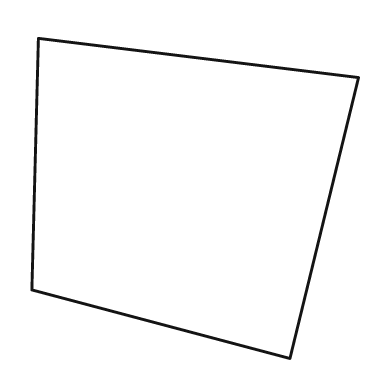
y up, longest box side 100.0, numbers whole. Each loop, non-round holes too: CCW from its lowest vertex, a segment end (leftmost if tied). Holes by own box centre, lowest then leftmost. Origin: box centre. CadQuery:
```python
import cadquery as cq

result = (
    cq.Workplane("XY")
    .moveTo(29.0, -49.0)
    .lineTo(50.0, 37.0)
    .lineTo(-48.0, 49.0)
    .lineTo(-50.0, -28.0)
    .close()
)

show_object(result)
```